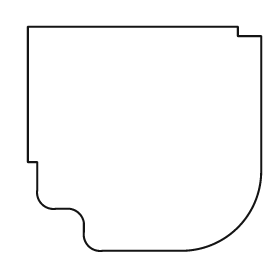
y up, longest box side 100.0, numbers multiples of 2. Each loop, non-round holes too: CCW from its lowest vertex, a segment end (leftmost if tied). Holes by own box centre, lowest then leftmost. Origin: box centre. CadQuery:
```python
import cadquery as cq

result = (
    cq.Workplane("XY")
    .moveTo(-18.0, -48.0)
    .lineTo(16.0, -48.0)
    .threePointArc((40.0, -38.0), (50.0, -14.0))
    .lineTo(50.0, 44.0)
    .lineTo(40.0, 44.0)
    .lineTo(40.0, 48.0)
    .lineTo(-50.0, 48.0)
    .lineTo(-50.0, -10.0)
    .lineTo(-46.0, -10.0)
    .lineTo(-46.0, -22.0)
    .threePointArc((-44.0, -28.0), (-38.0, -30.0))
    .lineTo(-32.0, -30.0)
    .threePointArc((-28.0, -32.0), (-26.0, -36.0))
    .lineTo(-26.0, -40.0)
    .threePointArc((-24.0, -46.0), (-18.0, -48.0))
    .close()
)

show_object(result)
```